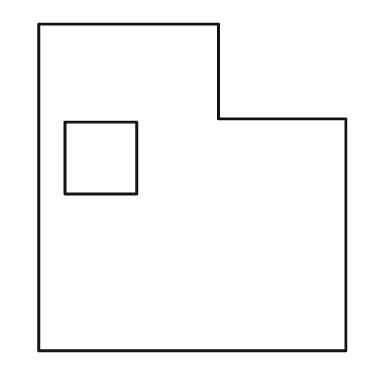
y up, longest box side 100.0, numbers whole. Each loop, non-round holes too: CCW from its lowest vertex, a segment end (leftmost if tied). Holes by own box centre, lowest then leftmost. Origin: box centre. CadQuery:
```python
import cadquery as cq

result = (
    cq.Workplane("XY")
    .moveTo(-47.0, -50.0)
    .lineTo(47.0, -50.0)
    .lineTo(47.0, 21.0)
    .lineTo(8.0, 21.0)
    .lineTo(8.0, 50.0)
    .lineTo(-47.0, 50.0)
    .close()
    .moveTo(-39.0, -2.0)
    .lineTo(-17.0, -2.0)
    .lineTo(-17.0, 20.0)
    .lineTo(-39.0, 20.0)
    .close()
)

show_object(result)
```